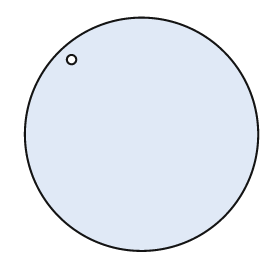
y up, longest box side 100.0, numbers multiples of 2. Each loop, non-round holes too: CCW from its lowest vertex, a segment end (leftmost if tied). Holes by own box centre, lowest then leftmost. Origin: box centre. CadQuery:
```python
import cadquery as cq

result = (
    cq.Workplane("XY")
    .moveTo(0.0, 0.0)
    .circle(50.0)
    .moveTo(-30.0, 32.0)
    .circle(2.0)
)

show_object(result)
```